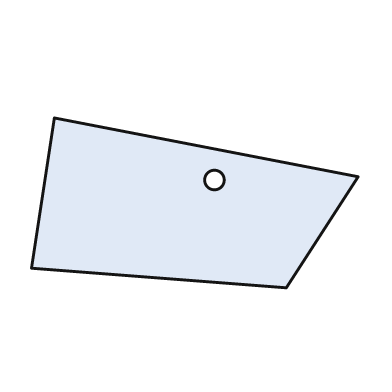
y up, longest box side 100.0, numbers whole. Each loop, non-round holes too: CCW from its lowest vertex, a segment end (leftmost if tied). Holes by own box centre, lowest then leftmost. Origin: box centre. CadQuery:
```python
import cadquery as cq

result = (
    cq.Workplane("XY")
    .moveTo(28.0, -26.0)
    .lineTo(50.0, 8.0)
    .lineTo(-43.0, 26.0)
    .lineTo(-50.0, -20.0)
    .close()
    .moveTo(6.0, 7.0)
    .circle(3.0)
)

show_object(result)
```